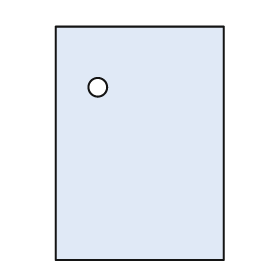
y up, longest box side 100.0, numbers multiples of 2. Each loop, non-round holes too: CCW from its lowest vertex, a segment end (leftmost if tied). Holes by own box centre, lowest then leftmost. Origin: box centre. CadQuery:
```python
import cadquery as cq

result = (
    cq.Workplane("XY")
    .moveTo(-36.0, -50.0)
    .lineTo(36.0, -50.0)
    .lineTo(36.0, 50.0)
    .lineTo(-36.0, 50.0)
    .close()
    .moveTo(-18.0, 24.0)
    .circle(4.0)
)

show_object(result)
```